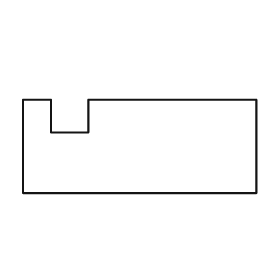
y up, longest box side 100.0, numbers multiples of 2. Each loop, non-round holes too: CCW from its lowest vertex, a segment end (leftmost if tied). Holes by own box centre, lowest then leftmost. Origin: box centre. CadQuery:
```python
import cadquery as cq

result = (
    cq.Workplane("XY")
    .moveTo(-50.0, -20.0)
    .lineTo(50.0, -20.0)
    .lineTo(50.0, 20.0)
    .lineTo(-22.0, 20.0)
    .lineTo(-22.0, 6.0)
    .lineTo(-38.0, 6.0)
    .lineTo(-38.0, 20.0)
    .lineTo(-50.0, 20.0)
    .close()
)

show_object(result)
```